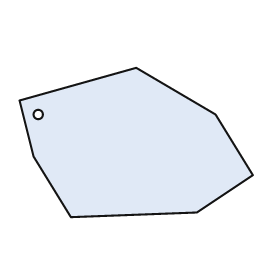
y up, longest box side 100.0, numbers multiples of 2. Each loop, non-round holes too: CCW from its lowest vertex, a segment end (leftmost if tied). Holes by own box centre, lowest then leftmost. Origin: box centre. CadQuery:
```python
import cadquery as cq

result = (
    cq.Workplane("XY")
    .moveTo(-28.0, -32.0)
    .lineTo(26.0, -30.0)
    .lineTo(50.0, -14.0)
    .lineTo(34.0, 12.0)
    .lineTo(0.0, 32.0)
    .lineTo(-50.0, 18.0)
    .lineTo(-44.0, -6.0)
    .close()
    .moveTo(-42.0, 12.0)
    .circle(2.0)
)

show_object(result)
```